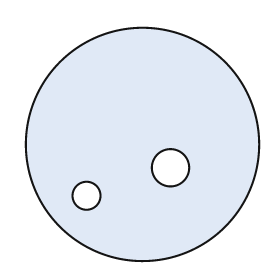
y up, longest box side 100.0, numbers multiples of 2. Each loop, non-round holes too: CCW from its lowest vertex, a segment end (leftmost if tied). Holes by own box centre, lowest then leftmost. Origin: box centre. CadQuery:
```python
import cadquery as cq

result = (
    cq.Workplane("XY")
    .moveTo(0.0, 0.0)
    .circle(50.0)
    .moveTo(-24.0, -22.0)
    .circle(6.0)
    .moveTo(12.0, -10.0)
    .circle(8.0)
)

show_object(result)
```